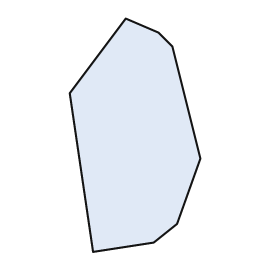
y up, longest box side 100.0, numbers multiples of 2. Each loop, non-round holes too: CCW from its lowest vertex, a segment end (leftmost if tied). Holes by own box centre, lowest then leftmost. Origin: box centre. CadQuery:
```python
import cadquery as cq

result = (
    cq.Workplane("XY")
    .moveTo(-18.0, -50.0)
    .lineTo(8.0, -46.0)
    .lineTo(18.0, -38.0)
    .lineTo(28.0, -10.0)
    .lineTo(16.0, 38.0)
    .lineTo(10.0, 44.0)
    .lineTo(-4.0, 50.0)
    .lineTo(-28.0, 18.0)
    .close()
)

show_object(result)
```